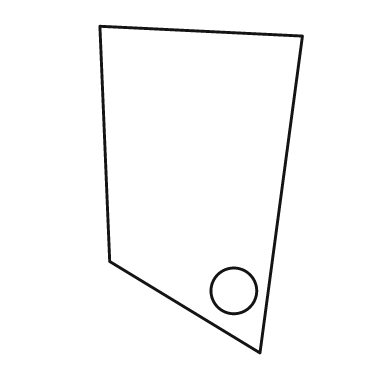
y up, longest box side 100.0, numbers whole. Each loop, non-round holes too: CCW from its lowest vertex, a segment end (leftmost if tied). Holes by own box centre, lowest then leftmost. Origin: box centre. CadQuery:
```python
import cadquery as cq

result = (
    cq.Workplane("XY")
    .moveTo(18.0, -50.0)
    .lineTo(31.0, 47.0)
    .lineTo(-31.0, 50.0)
    .lineTo(-28.0, -22.0)
    .close()
    .moveTo(10.0, -31.0)
    .circle(7.0)
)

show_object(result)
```